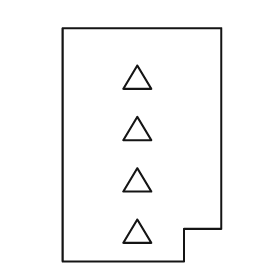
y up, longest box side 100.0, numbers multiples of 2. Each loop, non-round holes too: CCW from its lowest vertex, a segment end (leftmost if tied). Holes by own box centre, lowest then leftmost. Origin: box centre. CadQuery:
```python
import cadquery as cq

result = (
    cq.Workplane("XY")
    .moveTo(-34.0, -50.0)
    .lineTo(18.0, -50.0)
    .lineTo(18.0, -36.0)
    .lineTo(34.0, -36.0)
    .lineTo(34.0, 50.0)
    .lineTo(-34.0, 50.0)
    .close()
    .moveTo(-8.0, -42.0)
    .lineTo(4.0, -42.0)
    .lineTo(-2.0, -32.0)
    .close()
    .moveTo(-8.0, -20.0)
    .lineTo(4.0, -20.0)
    .lineTo(-2.0, -10.0)
    .close()
    .moveTo(-8.0, 2.0)
    .lineTo(4.0, 2.0)
    .lineTo(-2.0, 12.0)
    .close()
    .moveTo(-8.0, 24.0)
    .lineTo(4.0, 24.0)
    .lineTo(-2.0, 34.0)
    .close()
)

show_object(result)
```